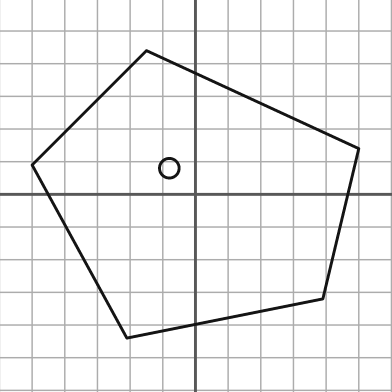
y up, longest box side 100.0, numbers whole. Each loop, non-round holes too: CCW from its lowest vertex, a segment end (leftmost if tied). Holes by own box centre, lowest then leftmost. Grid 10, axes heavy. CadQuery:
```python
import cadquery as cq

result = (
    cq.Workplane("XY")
    .moveTo(-21.0, -44.0)
    .lineTo(39.0, -32.0)
    .lineTo(50.0, 14.0)
    .lineTo(-15.0, 44.0)
    .lineTo(-50.0, 9.0)
    .close()
    .moveTo(-8.0, 8.0)
    .circle(3.0)
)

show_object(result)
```